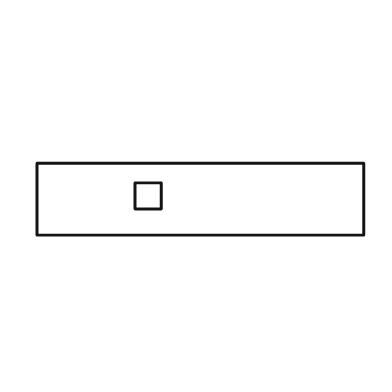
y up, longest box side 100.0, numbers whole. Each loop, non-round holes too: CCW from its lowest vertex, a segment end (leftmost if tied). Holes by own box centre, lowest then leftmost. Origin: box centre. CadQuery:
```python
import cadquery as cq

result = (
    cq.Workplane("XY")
    .moveTo(-50.0, -11.0)
    .lineTo(50.0, -11.0)
    .lineTo(50.0, 11.0)
    .lineTo(-50.0, 11.0)
    .close()
    .moveTo(-20.0, -3.0)
    .lineTo(-12.0, -3.0)
    .lineTo(-12.0, 5.0)
    .lineTo(-20.0, 5.0)
    .close()
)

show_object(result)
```